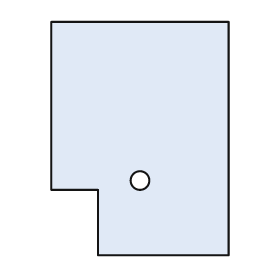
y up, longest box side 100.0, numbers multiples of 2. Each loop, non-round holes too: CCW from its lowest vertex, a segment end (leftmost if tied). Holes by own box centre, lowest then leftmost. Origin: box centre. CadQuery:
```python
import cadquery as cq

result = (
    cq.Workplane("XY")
    .moveTo(-18.0, -50.0)
    .lineTo(38.0, -50.0)
    .lineTo(38.0, 50.0)
    .lineTo(-38.0, 50.0)
    .lineTo(-38.0, -22.0)
    .lineTo(-18.0, -22.0)
    .close()
    .moveTo(0.0, -18.0)
    .circle(4.0)
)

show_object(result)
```